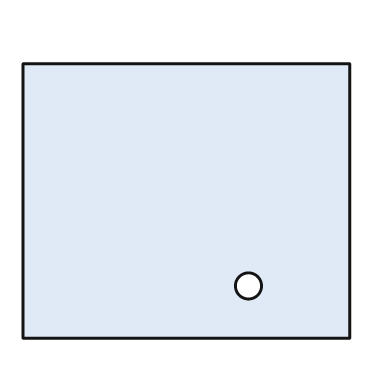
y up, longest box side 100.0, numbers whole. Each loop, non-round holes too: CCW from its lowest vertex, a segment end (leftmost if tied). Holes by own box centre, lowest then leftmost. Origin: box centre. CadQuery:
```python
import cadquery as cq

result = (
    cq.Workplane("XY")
    .moveTo(-50.0, -42.0)
    .lineTo(50.0, -42.0)
    .lineTo(50.0, 42.0)
    .lineTo(-50.0, 42.0)
    .close()
    .moveTo(19.0, -26.0)
    .circle(4.0)
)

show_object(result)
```